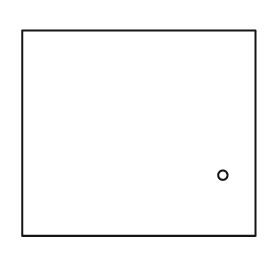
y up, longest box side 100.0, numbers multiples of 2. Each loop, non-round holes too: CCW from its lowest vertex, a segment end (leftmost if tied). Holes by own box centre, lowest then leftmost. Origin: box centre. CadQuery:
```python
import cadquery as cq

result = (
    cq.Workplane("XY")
    .moveTo(-50.0, -44.0)
    .lineTo(50.0, -44.0)
    .lineTo(50.0, 44.0)
    .lineTo(-50.0, 44.0)
    .close()
    .moveTo(36.0, -18.0)
    .circle(2.0)
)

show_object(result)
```